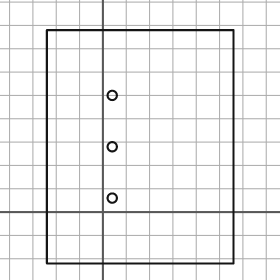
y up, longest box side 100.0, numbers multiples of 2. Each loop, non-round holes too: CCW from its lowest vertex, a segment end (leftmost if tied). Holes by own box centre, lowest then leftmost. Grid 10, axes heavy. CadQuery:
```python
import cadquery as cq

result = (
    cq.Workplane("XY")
    .moveTo(-24.0, -22.0)
    .lineTo(56.0, -22.0)
    .lineTo(56.0, 78.0)
    .lineTo(-24.0, 78.0)
    .close()
    .moveTo(4.0, 6.0)
    .circle(2.0)
    .moveTo(4.0, 28.0)
    .circle(2.0)
    .moveTo(4.0, 50.0)
    .circle(2.0)
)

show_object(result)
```